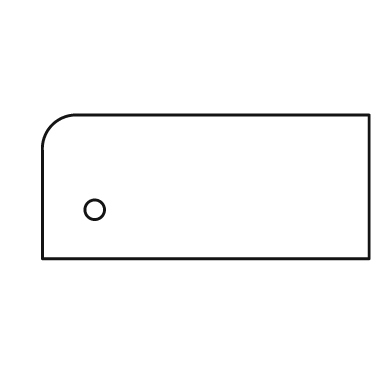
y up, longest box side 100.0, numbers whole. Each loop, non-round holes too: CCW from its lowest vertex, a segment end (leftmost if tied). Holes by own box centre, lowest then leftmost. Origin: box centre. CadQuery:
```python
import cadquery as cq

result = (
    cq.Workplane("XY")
    .moveTo(-50.0, -22.0)
    .lineTo(50.0, -22.0)
    .lineTo(50.0, 22.0)
    .lineTo(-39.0, 22.0)
    .threePointArc((-47.0, 19.0), (-50.0, 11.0))
    .close()
    .moveTo(-34.0, -7.0)
    .circle(3.0)
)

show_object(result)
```